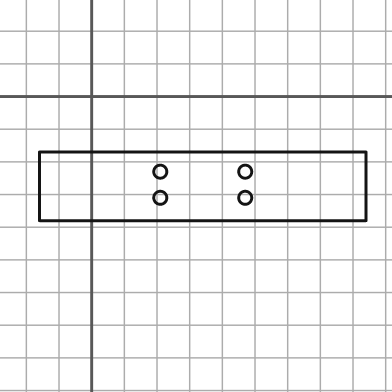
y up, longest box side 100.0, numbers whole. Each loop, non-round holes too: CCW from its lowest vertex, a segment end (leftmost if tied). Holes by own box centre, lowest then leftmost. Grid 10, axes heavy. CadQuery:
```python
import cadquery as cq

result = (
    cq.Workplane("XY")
    .moveTo(-16.0, -38.0)
    .lineTo(84.0, -38.0)
    .lineTo(84.0, -17.0)
    .lineTo(-16.0, -17.0)
    .close()
    .moveTo(21.0, -31.0)
    .circle(2.0)
    .moveTo(47.0, -31.0)
    .circle(2.0)
    .moveTo(21.0, -23.0)
    .circle(2.0)
    .moveTo(47.0, -23.0)
    .circle(2.0)
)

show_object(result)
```